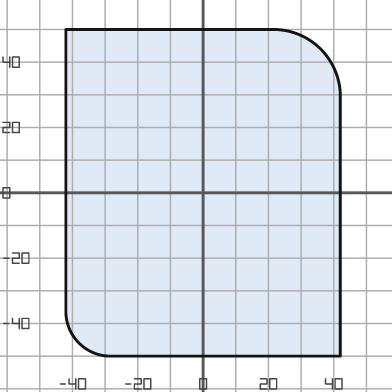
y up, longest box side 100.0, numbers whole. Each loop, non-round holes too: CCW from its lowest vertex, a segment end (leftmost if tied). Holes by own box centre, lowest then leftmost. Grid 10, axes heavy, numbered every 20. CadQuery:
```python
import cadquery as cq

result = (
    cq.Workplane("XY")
    .moveTo(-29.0, -50.0)
    .lineTo(42.0, -50.0)
    .lineTo(42.0, 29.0)
    .threePointArc((36.0, 44.0), (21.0, 50.0))
    .lineTo(-42.0, 50.0)
    .lineTo(-42.0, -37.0)
    .threePointArc((-38.0, -46.0), (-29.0, -50.0))
    .close()
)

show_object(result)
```